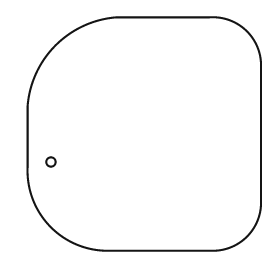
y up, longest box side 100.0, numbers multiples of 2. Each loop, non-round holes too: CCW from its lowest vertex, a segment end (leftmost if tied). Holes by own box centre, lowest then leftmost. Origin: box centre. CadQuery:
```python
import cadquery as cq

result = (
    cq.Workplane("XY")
    .moveTo(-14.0, -50.0)
    .lineTo(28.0, -50.0)
    .threePointArc((44.0, -44.0), (50.0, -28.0))
    .lineTo(50.0, 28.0)
    .threePointArc((44.0, 44.0), (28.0, 50.0))
    .lineTo(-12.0, 50.0)
    .threePointArc((-38.0, 38.0), (-50.0, 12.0))
    .lineTo(-50.0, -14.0)
    .threePointArc((-40.0, -40.0), (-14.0, -50.0))
    .close()
    .moveTo(-40.0, -12.0)
    .circle(2.0)
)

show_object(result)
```